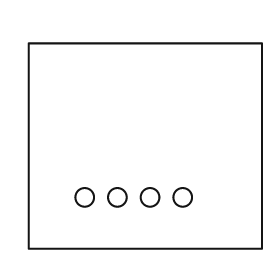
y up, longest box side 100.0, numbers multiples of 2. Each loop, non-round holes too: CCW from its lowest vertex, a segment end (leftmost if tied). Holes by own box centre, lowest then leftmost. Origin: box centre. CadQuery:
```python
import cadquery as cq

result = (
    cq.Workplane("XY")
    .moveTo(-50.0, -44.0)
    .lineTo(50.0, -44.0)
    .lineTo(50.0, 44.0)
    .lineTo(-50.0, 44.0)
    .close()
    .moveTo(-26.0, -22.0)
    .circle(4.0)
    .moveTo(-12.0, -22.0)
    .circle(4.0)
    .moveTo(2.0, -22.0)
    .circle(4.0)
    .moveTo(16.0, -22.0)
    .circle(4.0)
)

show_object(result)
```